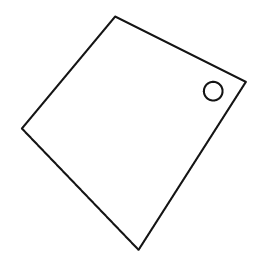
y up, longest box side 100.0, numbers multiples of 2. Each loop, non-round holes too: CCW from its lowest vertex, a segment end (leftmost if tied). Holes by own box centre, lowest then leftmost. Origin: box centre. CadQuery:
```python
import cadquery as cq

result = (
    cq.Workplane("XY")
    .moveTo(2.0, -50.0)
    .lineTo(48.0, 22.0)
    .lineTo(-8.0, 50.0)
    .lineTo(-48.0, 2.0)
    .close()
    .moveTo(34.0, 18.0)
    .circle(4.0)
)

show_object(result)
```